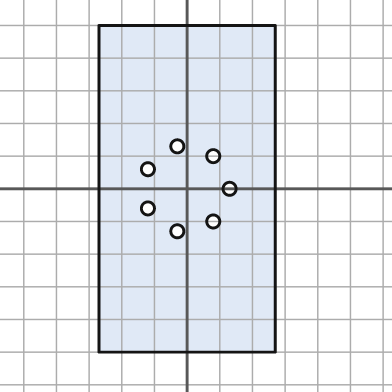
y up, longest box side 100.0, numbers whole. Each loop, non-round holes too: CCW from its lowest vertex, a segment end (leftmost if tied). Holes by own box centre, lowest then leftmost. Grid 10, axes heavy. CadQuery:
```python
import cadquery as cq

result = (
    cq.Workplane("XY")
    .moveTo(-27.0, -50.0)
    .lineTo(27.0, -50.0)
    .lineTo(27.0, 50.0)
    .lineTo(-27.0, 50.0)
    .close()
    .moveTo(-3.0, -13.0)
    .circle(2.0)
    .moveTo(8.0, -10.0)
    .circle(2.0)
    .moveTo(-12.0, -6.0)
    .circle(2.0)
    .moveTo(13.0, 0.0)
    .circle(2.0)
    .moveTo(-12.0, 6.0)
    .circle(2.0)
    .moveTo(8.0, 10.0)
    .circle(2.0)
    .moveTo(-3.0, 13.0)
    .circle(2.0)
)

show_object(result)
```